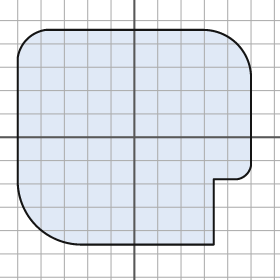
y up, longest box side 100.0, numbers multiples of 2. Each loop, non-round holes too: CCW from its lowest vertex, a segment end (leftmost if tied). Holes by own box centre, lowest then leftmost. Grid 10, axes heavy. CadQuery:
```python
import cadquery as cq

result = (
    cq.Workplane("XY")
    .moveTo(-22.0, -46.0)
    .lineTo(34.0, -46.0)
    .lineTo(34.0, -18.0)
    .lineTo(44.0, -18.0)
    .threePointArc((48.0, -16.0), (50.0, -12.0))
    .lineTo(50.0, 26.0)
    .threePointArc((44.0, 40.0), (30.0, 46.0))
    .lineTo(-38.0, 46.0)
    .threePointArc((-46.0, 42.0), (-50.0, 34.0))
    .lineTo(-50.0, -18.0)
    .threePointArc((-42.0, -38.0), (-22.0, -46.0))
    .close()
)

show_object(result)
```